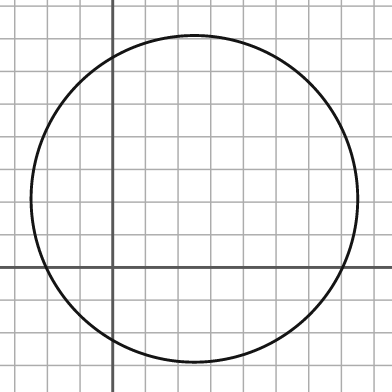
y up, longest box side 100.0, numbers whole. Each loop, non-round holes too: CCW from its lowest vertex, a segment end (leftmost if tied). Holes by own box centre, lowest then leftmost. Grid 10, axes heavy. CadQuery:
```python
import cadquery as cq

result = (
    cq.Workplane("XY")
    .moveTo(25.0, 21.0)
    .circle(50.0)
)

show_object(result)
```